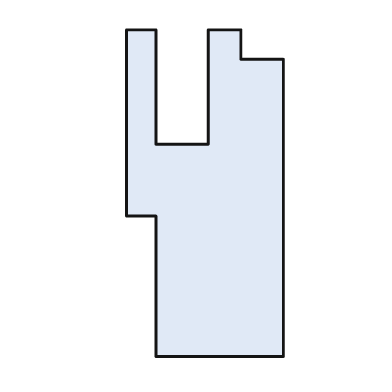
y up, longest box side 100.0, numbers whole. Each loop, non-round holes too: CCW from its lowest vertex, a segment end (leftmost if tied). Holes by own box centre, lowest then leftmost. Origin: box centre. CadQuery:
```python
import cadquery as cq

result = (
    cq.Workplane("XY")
    .moveTo(-15.0, -50.0)
    .lineTo(24.0, -50.0)
    .lineTo(24.0, 41.0)
    .lineTo(11.0, 41.0)
    .lineTo(11.0, 50.0)
    .lineTo(1.0, 50.0)
    .lineTo(1.0, 15.0)
    .lineTo(-15.0, 15.0)
    .lineTo(-15.0, 50.0)
    .lineTo(-24.0, 50.0)
    .lineTo(-24.0, -7.0)
    .lineTo(-15.0, -7.0)
    .close()
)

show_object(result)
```